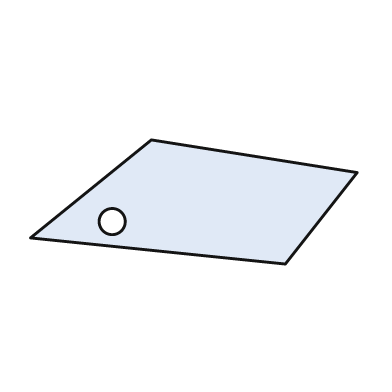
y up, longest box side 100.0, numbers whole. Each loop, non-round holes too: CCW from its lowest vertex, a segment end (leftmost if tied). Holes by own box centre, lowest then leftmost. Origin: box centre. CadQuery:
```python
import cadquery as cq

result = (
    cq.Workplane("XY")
    .moveTo(28.0, -19.0)
    .lineTo(50.0, 9.0)
    .lineTo(-13.0, 19.0)
    .lineTo(-50.0, -11.0)
    .close()
    .moveTo(-25.0, -6.0)
    .circle(4.0)
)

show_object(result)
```